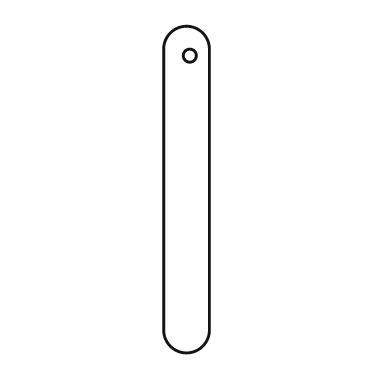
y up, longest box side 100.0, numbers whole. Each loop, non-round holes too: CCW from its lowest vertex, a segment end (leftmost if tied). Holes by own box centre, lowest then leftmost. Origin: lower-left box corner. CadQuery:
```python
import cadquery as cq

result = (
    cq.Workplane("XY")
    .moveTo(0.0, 7.0)
    .threePointArc((7.0, 0.0), (14.0, 7.0))
    .lineTo(14.0, 93.0)
    .threePointArc((7.0, 100.0), (0.0, 93.0))
    .close()
    .moveTo(8.0, 91.0)
    .circle(2.0)
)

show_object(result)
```